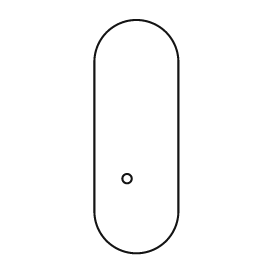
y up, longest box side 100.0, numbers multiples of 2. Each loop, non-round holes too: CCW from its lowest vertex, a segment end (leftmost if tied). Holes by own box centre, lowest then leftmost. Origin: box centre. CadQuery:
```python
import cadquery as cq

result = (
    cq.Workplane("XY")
    .moveTo(-18.0, -32.0)
    .threePointArc((0.0, -50.0), (18.0, -32.0))
    .lineTo(18.0, 32.0)
    .threePointArc((0.0, 50.0), (-18.0, 32.0))
    .close()
    .moveTo(-4.0, -18.0)
    .circle(2.0)
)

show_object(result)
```